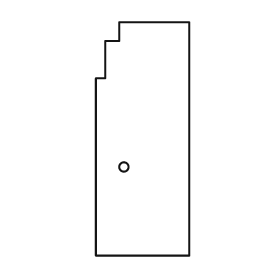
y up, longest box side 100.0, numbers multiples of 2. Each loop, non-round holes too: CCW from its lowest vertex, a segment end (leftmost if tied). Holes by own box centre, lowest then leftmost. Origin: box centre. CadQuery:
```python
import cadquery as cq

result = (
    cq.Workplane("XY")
    .moveTo(-20.0, -50.0)
    .lineTo(20.0, -50.0)
    .lineTo(20.0, 50.0)
    .lineTo(-10.0, 50.0)
    .lineTo(-10.0, 42.0)
    .lineTo(-16.0, 42.0)
    .lineTo(-16.0, 26.0)
    .lineTo(-20.0, 26.0)
    .close()
    .moveTo(-8.0, -12.0)
    .circle(2.0)
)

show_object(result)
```